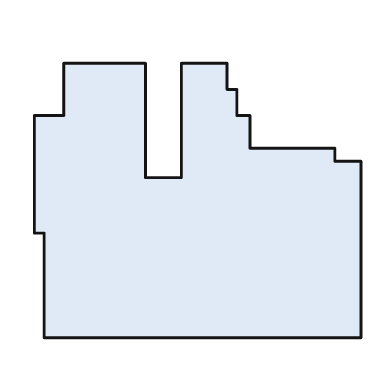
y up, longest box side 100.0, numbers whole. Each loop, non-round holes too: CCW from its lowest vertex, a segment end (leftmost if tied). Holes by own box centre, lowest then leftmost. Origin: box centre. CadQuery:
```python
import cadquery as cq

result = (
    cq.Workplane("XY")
    .moveTo(-47.0, -42.0)
    .lineTo(50.0, -42.0)
    .lineTo(50.0, 12.0)
    .lineTo(42.0, 12.0)
    .lineTo(42.0, 16.0)
    .lineTo(16.0, 16.0)
    .lineTo(16.0, 26.0)
    .lineTo(12.0, 26.0)
    .lineTo(12.0, 34.0)
    .lineTo(9.0, 34.0)
    .lineTo(9.0, 42.0)
    .lineTo(-5.0, 42.0)
    .lineTo(-5.0, 7.0)
    .lineTo(-16.0, 7.0)
    .lineTo(-16.0, 42.0)
    .lineTo(-41.0, 42.0)
    .lineTo(-41.0, 26.0)
    .lineTo(-50.0, 26.0)
    .lineTo(-50.0, -10.0)
    .lineTo(-47.0, -10.0)
    .close()
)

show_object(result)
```